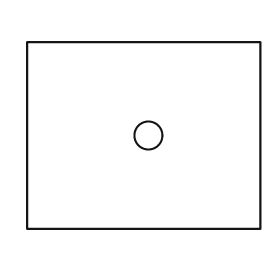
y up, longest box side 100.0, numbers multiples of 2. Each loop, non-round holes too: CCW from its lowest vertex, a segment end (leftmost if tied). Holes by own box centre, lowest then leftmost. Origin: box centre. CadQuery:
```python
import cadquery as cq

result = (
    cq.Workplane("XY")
    .moveTo(-50.0, -40.0)
    .lineTo(50.0, -40.0)
    .lineTo(50.0, 40.0)
    .lineTo(-50.0, 40.0)
    .close()
    .moveTo(2.0, 0.0)
    .circle(6.0)
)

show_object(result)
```